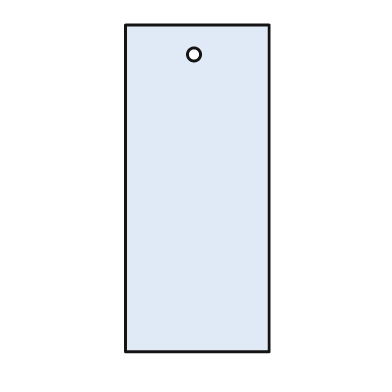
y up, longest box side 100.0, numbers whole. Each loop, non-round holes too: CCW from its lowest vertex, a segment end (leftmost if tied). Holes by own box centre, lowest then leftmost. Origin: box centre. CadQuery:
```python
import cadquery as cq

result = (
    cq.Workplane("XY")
    .moveTo(-22.0, -50.0)
    .lineTo(22.0, -50.0)
    .lineTo(22.0, 50.0)
    .lineTo(-22.0, 50.0)
    .close()
    .moveTo(-1.0, 41.0)
    .circle(2.0)
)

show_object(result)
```